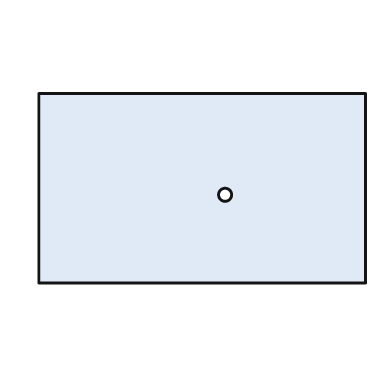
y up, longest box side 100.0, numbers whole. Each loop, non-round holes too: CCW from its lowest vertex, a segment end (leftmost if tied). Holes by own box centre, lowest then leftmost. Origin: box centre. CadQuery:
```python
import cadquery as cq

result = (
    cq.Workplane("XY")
    .moveTo(-50.0, -29.0)
    .lineTo(50.0, -29.0)
    .lineTo(50.0, 29.0)
    .lineTo(-50.0, 29.0)
    .close()
    .moveTo(7.0, -2.0)
    .circle(2.0)
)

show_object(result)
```